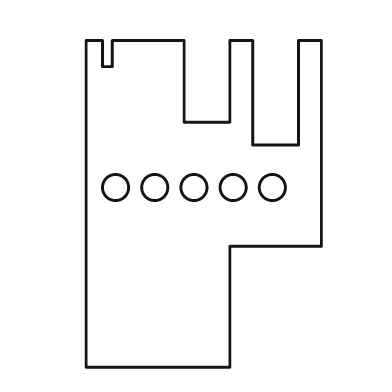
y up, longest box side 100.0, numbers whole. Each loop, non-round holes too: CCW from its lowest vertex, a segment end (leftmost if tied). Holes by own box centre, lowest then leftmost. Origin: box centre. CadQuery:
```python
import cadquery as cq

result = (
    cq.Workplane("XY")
    .moveTo(-36.0, -50.0)
    .lineTo(8.0, -50.0)
    .lineTo(8.0, -13.0)
    .lineTo(36.0, -13.0)
    .lineTo(36.0, 50.0)
    .lineTo(29.0, 50.0)
    .lineTo(29.0, 18.0)
    .lineTo(15.0, 18.0)
    .lineTo(15.0, 50.0)
    .lineTo(8.0, 50.0)
    .lineTo(8.0, 25.0)
    .lineTo(-6.0, 25.0)
    .lineTo(-6.0, 50.0)
    .lineTo(-28.0, 50.0)
    .lineTo(-28.0, 42.0)
    .lineTo(-31.0, 42.0)
    .lineTo(-31.0, 50.0)
    .lineTo(-36.0, 50.0)
    .close()
    .moveTo(-27.0, 5.0)
    .circle(4.0)
    .moveTo(-15.0, 5.0)
    .circle(4.0)
    .moveTo(-3.0, 5.0)
    .circle(4.0)
    .moveTo(9.0, 5.0)
    .circle(4.0)
    .moveTo(21.0, 5.0)
    .circle(4.0)
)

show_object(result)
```